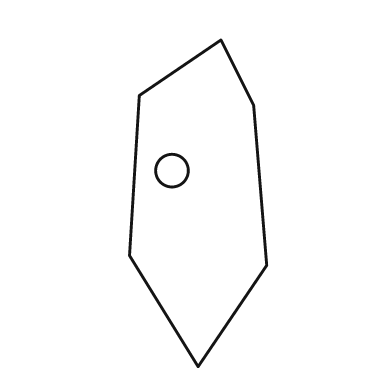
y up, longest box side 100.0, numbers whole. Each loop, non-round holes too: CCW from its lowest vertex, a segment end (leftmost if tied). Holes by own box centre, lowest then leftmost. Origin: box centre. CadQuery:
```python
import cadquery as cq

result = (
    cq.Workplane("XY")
    .moveTo(0.0, -50.0)
    .lineTo(21.0, -19.0)
    .lineTo(17.0, 30.0)
    .lineTo(7.0, 50.0)
    .lineTo(-18.0, 33.0)
    .lineTo(-21.0, -16.0)
    .close()
    .moveTo(-8.0, 10.0)
    .circle(5.0)
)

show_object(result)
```